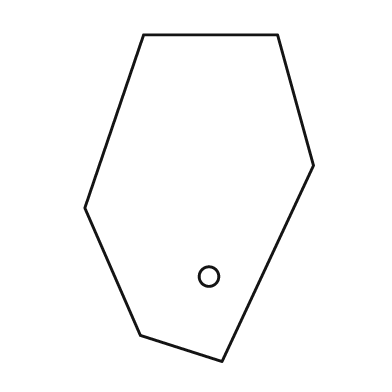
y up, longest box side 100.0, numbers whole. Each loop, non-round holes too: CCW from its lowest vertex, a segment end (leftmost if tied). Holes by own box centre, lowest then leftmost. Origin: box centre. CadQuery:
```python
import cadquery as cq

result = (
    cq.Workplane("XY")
    .moveTo(7.0, -50.0)
    .lineTo(35.0, 10.0)
    .lineTo(24.0, 50.0)
    .lineTo(-17.0, 50.0)
    .lineTo(-35.0, -3.0)
    .lineTo(-18.0, -42.0)
    .close()
    .moveTo(3.0, -24.0)
    .circle(3.0)
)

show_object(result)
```